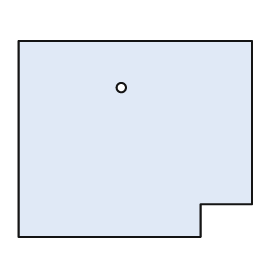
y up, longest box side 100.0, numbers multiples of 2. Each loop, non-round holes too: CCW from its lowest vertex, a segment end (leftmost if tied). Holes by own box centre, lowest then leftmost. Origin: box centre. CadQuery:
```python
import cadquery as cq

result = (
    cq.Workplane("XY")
    .moveTo(-50.0, -42.0)
    .lineTo(28.0, -42.0)
    .lineTo(28.0, -28.0)
    .lineTo(50.0, -28.0)
    .lineTo(50.0, 42.0)
    .lineTo(-50.0, 42.0)
    .close()
    .moveTo(-6.0, 22.0)
    .circle(2.0)
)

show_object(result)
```